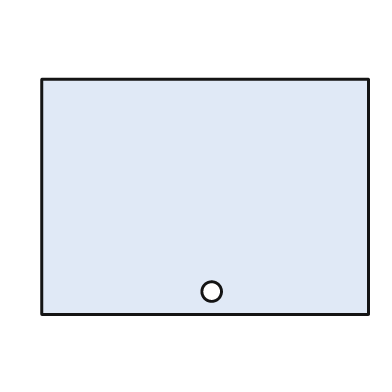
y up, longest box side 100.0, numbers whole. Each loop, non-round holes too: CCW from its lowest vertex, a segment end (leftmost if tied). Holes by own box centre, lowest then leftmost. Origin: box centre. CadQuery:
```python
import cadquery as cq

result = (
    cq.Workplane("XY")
    .moveTo(-50.0, -36.0)
    .lineTo(50.0, -36.0)
    .lineTo(50.0, 36.0)
    .lineTo(-50.0, 36.0)
    .close()
    .moveTo(2.0, -29.0)
    .circle(3.0)
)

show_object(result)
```